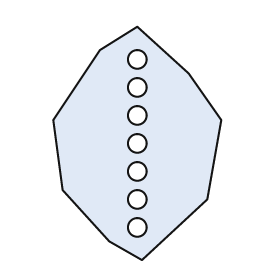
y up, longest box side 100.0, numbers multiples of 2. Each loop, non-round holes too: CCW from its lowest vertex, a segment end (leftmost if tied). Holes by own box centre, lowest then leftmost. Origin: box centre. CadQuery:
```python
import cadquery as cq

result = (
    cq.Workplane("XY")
    .moveTo(2.0, -50.0)
    .lineTo(30.0, -24.0)
    .lineTo(36.0, 10.0)
    .lineTo(22.0, 30.0)
    .lineTo(0.0, 50.0)
    .lineTo(-16.0, 40.0)
    .lineTo(-36.0, 10.0)
    .lineTo(-32.0, -20.0)
    .lineTo(-12.0, -42.0)
    .close()
    .moveTo(0.0, -36.0)
    .circle(4.0)
    .moveTo(0.0, -24.0)
    .circle(4.0)
    .moveTo(0.0, -12.0)
    .circle(4.0)
    .moveTo(0.0, 0.0)
    .circle(4.0)
    .moveTo(0.0, 12.0)
    .circle(4.0)
    .moveTo(0.0, 24.0)
    .circle(4.0)
    .moveTo(0.0, 36.0)
    .circle(4.0)
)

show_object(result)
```